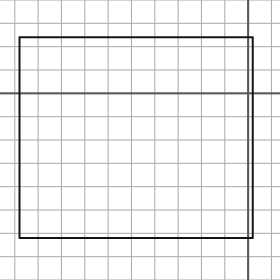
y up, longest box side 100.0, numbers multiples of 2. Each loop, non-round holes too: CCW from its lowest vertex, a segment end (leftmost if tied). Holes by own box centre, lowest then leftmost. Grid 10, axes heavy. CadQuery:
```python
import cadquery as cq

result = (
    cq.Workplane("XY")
    .moveTo(-98.0, -62.0)
    .lineTo(2.0, -62.0)
    .lineTo(2.0, 24.0)
    .lineTo(-98.0, 24.0)
    .close()
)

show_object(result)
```